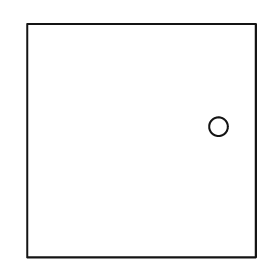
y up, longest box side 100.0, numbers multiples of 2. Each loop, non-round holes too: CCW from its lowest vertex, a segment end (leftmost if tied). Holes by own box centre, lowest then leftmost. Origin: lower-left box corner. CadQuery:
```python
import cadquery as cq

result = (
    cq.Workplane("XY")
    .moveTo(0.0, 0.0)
    .lineTo(98.0, 0.0)
    .lineTo(98.0, 100.0)
    .lineTo(0.0, 100.0)
    .close()
    .moveTo(82.0, 56.0)
    .circle(4.0)
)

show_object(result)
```